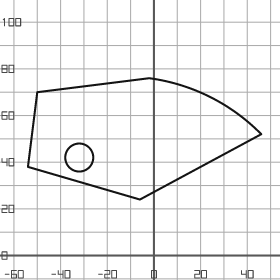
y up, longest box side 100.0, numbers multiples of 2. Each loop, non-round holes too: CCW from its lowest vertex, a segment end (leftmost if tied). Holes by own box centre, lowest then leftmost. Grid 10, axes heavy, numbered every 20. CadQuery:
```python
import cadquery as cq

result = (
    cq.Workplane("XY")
    .moveTo(-6.0, 24.0)
    .lineTo(46.0, 52.0)
    .threePointArc((24.0, 68.0), (-2.0, 76.0))
    .lineTo(-50.0, 70.0)
    .lineTo(-54.0, 38.0)
    .close()
    .moveTo(-32.0, 42.0)
    .circle(6.0)
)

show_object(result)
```